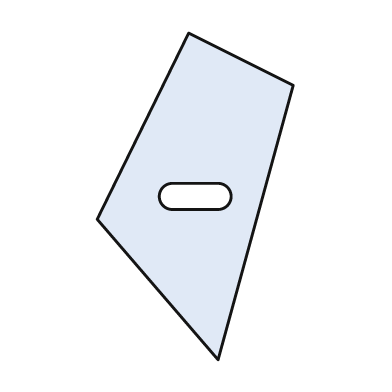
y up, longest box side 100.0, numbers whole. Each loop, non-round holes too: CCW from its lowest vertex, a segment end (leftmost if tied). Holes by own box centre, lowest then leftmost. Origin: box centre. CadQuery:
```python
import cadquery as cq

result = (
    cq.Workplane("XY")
    .moveTo(7.0, -50.0)
    .lineTo(30.0, 34.0)
    .lineTo(-2.0, 50.0)
    .lineTo(-30.0, -7.0)
    .close()
    .moveTo(-7.0, -4.0)
    .lineTo(7.0, -4.0)
    .threePointArc((11.0, 0.0), (7.0, 4.0))
    .lineTo(-7.0, 4.0)
    .threePointArc((-11.0, 0.0), (-7.0, -4.0))
    .close()
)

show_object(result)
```